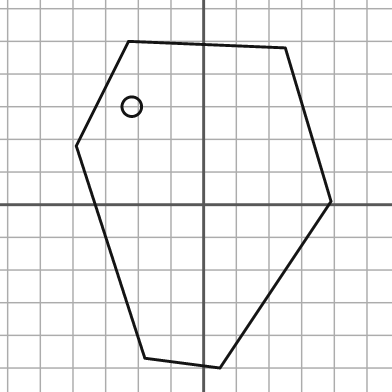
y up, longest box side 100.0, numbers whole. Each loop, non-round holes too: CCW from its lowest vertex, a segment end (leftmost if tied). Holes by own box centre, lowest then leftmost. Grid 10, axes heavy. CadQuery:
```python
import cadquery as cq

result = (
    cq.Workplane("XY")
    .moveTo(5.0, -50.0)
    .lineTo(39.0, 1.0)
    .lineTo(25.0, 48.0)
    .lineTo(-23.0, 50.0)
    .lineTo(-39.0, 18.0)
    .lineTo(-18.0, -47.0)
    .close()
    .moveTo(-22.0, 30.0)
    .circle(3.0)
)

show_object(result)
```